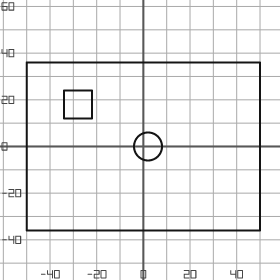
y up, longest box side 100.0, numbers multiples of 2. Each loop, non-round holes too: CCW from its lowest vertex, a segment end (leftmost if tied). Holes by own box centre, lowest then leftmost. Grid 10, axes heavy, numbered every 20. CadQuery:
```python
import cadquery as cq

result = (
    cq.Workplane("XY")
    .moveTo(-50.0, -36.0)
    .lineTo(50.0, -36.0)
    .lineTo(50.0, 36.0)
    .lineTo(-50.0, 36.0)
    .close()
    .moveTo(2.0, 0.0)
    .circle(6.0)
    .moveTo(-34.0, 12.0)
    .lineTo(-22.0, 12.0)
    .lineTo(-22.0, 24.0)
    .lineTo(-34.0, 24.0)
    .close()
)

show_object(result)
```